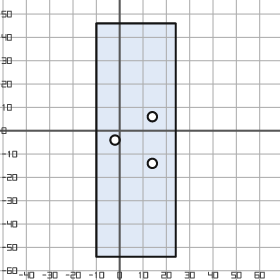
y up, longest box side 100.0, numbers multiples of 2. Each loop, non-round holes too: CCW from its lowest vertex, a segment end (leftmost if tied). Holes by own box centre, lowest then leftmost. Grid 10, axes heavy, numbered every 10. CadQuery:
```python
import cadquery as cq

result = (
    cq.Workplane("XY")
    .moveTo(-10.0, -54.0)
    .lineTo(24.0, -54.0)
    .lineTo(24.0, 46.0)
    .lineTo(-10.0, 46.0)
    .close()
    .moveTo(14.0, -14.0)
    .circle(2.0)
    .moveTo(-2.0, -4.0)
    .circle(2.0)
    .moveTo(14.0, 6.0)
    .circle(2.0)
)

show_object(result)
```